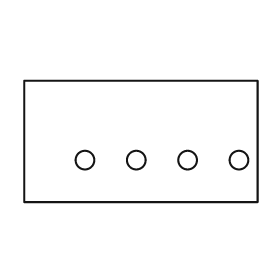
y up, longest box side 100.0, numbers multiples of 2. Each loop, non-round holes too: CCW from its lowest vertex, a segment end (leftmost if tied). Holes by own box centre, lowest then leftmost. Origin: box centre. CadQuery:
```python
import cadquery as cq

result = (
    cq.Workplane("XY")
    .moveTo(-50.0, -26.0)
    .lineTo(50.0, -26.0)
    .lineTo(50.0, 26.0)
    .lineTo(-50.0, 26.0)
    .close()
    .moveTo(-24.0, -8.0)
    .circle(4.0)
    .moveTo(-2.0, -8.0)
    .circle(4.0)
    .moveTo(20.0, -8.0)
    .circle(4.0)
    .moveTo(42.0, -8.0)
    .circle(4.0)
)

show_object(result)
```